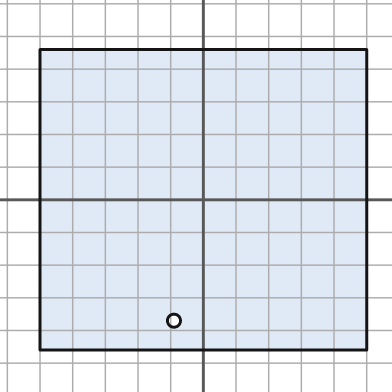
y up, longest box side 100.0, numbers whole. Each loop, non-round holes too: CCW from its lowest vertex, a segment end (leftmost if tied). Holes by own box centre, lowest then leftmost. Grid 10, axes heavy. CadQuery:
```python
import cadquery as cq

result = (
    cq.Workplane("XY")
    .moveTo(-50.0, -46.0)
    .lineTo(50.0, -46.0)
    .lineTo(50.0, 46.0)
    .lineTo(-50.0, 46.0)
    .close()
    .moveTo(-9.0, -37.0)
    .circle(2.0)
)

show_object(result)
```